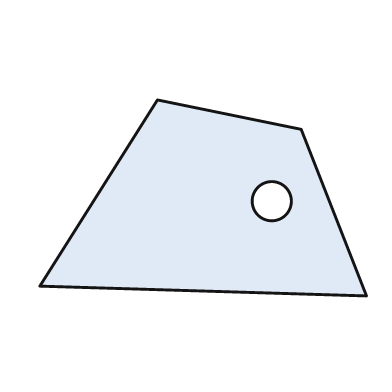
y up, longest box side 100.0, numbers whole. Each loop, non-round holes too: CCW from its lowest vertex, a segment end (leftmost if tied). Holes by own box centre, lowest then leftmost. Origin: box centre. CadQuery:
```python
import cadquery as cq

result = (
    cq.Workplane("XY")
    .moveTo(50.0, -30.0)
    .lineTo(30.0, 21.0)
    .lineTo(-14.0, 30.0)
    .lineTo(-50.0, -27.0)
    .close()
    .moveTo(21.0, -1.0)
    .circle(6.0)
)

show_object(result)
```